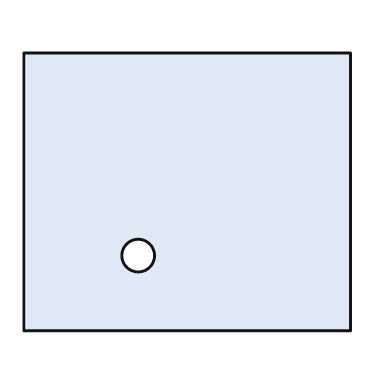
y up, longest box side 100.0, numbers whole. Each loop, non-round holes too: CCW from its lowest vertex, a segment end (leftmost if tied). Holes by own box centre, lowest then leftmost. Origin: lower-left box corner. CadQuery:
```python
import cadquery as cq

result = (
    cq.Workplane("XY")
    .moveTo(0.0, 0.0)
    .lineTo(100.0, 0.0)
    .lineTo(100.0, 85.0)
    .lineTo(0.0, 85.0)
    .close()
    .moveTo(35.0, 23.0)
    .circle(5.0)
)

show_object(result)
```